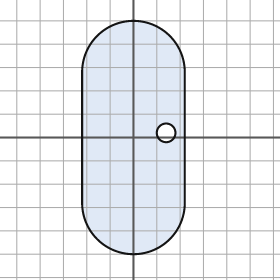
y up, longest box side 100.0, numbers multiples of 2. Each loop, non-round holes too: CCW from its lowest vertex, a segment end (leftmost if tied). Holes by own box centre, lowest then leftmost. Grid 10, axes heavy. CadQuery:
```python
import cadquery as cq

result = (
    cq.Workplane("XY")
    .moveTo(-22.0, -28.0)
    .threePointArc((0.0, -50.0), (22.0, -28.0))
    .lineTo(22.0, 28.0)
    .threePointArc((0.0, 50.0), (-22.0, 28.0))
    .close()
    .moveTo(14.0, 2.0)
    .circle(4.0)
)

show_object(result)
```